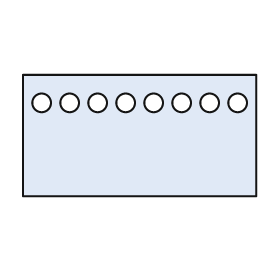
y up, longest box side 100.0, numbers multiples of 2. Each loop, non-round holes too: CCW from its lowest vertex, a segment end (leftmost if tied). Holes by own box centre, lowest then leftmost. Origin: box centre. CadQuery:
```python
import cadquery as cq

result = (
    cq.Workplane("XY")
    .moveTo(-50.0, -26.0)
    .lineTo(50.0, -26.0)
    .lineTo(50.0, 26.0)
    .lineTo(-50.0, 26.0)
    .close()
    .moveTo(-42.0, 14.0)
    .circle(4.0)
    .moveTo(-30.0, 14.0)
    .circle(4.0)
    .moveTo(-18.0, 14.0)
    .circle(4.0)
    .moveTo(-6.0, 14.0)
    .circle(4.0)
    .moveTo(6.0, 14.0)
    .circle(4.0)
    .moveTo(18.0, 14.0)
    .circle(4.0)
    .moveTo(30.0, 14.0)
    .circle(4.0)
    .moveTo(42.0, 14.0)
    .circle(4.0)
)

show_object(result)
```